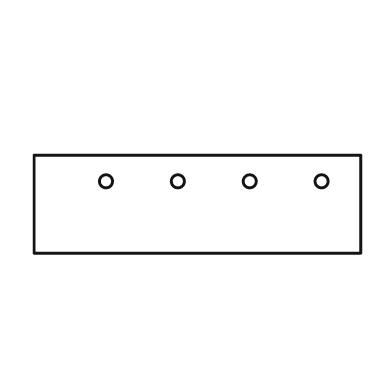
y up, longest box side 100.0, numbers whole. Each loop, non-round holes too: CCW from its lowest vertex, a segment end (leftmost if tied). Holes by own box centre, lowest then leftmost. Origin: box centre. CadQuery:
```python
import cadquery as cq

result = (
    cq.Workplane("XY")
    .moveTo(-50.0, -15.0)
    .lineTo(50.0, -15.0)
    .lineTo(50.0, 15.0)
    .lineTo(-50.0, 15.0)
    .close()
    .moveTo(-28.0, 7.0)
    .circle(2.0)
    .moveTo(-6.0, 7.0)
    .circle(2.0)
    .moveTo(16.0, 7.0)
    .circle(2.0)
    .moveTo(38.0, 7.0)
    .circle(2.0)
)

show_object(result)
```